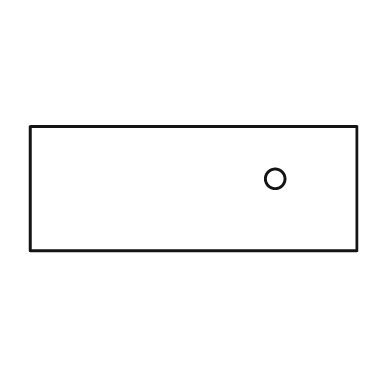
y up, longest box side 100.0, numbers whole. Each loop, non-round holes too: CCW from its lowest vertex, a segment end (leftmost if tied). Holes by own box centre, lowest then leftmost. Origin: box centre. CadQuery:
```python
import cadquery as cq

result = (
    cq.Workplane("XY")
    .moveTo(-50.0, -19.0)
    .lineTo(50.0, -19.0)
    .lineTo(50.0, 19.0)
    .lineTo(-50.0, 19.0)
    .close()
    .moveTo(25.0, 3.0)
    .circle(3.0)
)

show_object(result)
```